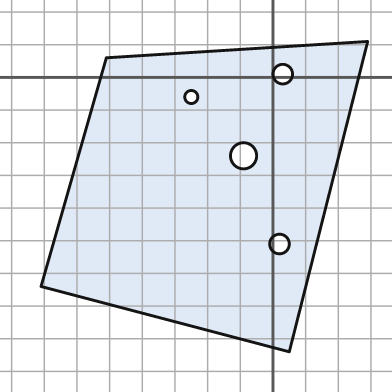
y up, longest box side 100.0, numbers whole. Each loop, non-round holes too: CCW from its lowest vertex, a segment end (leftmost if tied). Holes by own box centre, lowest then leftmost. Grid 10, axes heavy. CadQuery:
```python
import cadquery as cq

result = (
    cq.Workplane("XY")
    .moveTo(5.0, -84.0)
    .lineTo(29.0, 11.0)
    .lineTo(-51.0, 6.0)
    .lineTo(-71.0, -64.0)
    .close()
    .moveTo(2.0, -51.0)
    .circle(3.0)
    .moveTo(-9.0, -24.0)
    .circle(4.0)
    .moveTo(-25.0, -6.0)
    .circle(2.0)
    .moveTo(3.0, 1.0)
    .circle(3.0)
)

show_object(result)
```